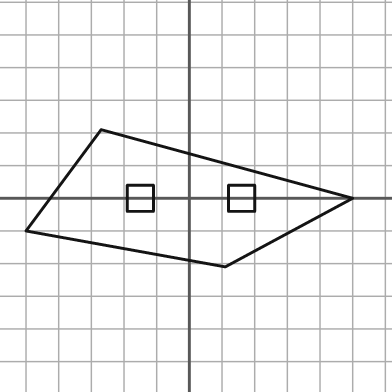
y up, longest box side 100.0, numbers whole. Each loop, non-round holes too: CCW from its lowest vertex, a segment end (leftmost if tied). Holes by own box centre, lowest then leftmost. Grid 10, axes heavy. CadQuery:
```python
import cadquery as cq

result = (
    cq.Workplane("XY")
    .moveTo(11.0, -21.0)
    .lineTo(50.0, 0.0)
    .lineTo(-27.0, 21.0)
    .lineTo(-50.0, -10.0)
    .close()
    .moveTo(-19.0, -4.0)
    .lineTo(-11.0, -4.0)
    .lineTo(-11.0, 4.0)
    .lineTo(-19.0, 4.0)
    .close()
    .moveTo(12.0, -4.0)
    .lineTo(20.0, -4.0)
    .lineTo(20.0, 4.0)
    .lineTo(12.0, 4.0)
    .close()
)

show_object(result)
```